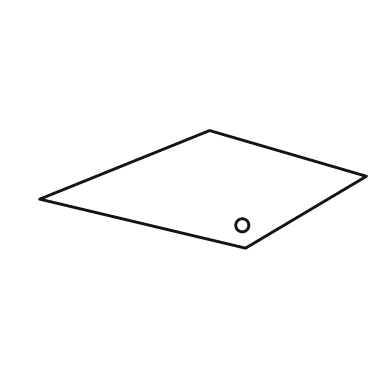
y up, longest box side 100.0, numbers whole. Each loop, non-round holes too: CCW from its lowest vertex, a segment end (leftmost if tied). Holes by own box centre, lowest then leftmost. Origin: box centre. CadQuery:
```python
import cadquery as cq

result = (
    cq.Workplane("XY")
    .moveTo(13.0, -18.0)
    .lineTo(50.0, 4.0)
    .lineTo(2.0, 18.0)
    .lineTo(-50.0, -3.0)
    .close()
    .moveTo(12.0, -11.0)
    .circle(2.0)
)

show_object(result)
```